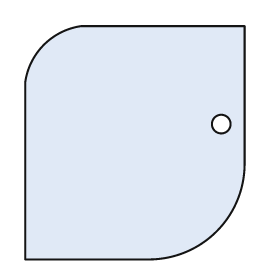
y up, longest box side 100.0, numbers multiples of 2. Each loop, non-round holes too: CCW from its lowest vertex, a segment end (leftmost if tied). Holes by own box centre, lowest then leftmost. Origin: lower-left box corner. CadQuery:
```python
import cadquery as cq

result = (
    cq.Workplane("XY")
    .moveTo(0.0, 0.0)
    .lineTo(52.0, 0.0)
    .threePointArc((82.0, 12.0), (94.0, 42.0))
    .lineTo(94.0, 100.0)
    .lineTo(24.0, 100.0)
    .threePointArc((8.0, 92.0), (0.0, 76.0))
    .close()
    .moveTo(84.0, 58.0)
    .circle(4.0)
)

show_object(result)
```